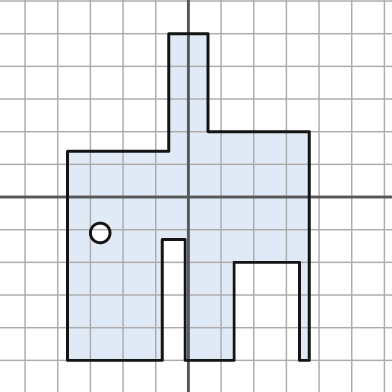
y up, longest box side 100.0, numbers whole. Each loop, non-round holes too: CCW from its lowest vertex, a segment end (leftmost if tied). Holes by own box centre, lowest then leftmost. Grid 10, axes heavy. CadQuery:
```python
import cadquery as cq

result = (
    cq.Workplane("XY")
    .moveTo(-37.0, -50.0)
    .lineTo(-8.0, -50.0)
    .lineTo(-8.0, -13.0)
    .lineTo(-1.0, -13.0)
    .lineTo(-1.0, -50.0)
    .lineTo(14.0, -50.0)
    .lineTo(14.0, -20.0)
    .lineTo(34.0, -20.0)
    .lineTo(34.0, -50.0)
    .lineTo(37.0, -50.0)
    .lineTo(37.0, 20.0)
    .lineTo(6.0, 20.0)
    .lineTo(6.0, 50.0)
    .lineTo(-6.0, 50.0)
    .lineTo(-6.0, 14.0)
    .lineTo(-37.0, 14.0)
    .close()
    .moveTo(-27.0, -11.0)
    .circle(3.0)
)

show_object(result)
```